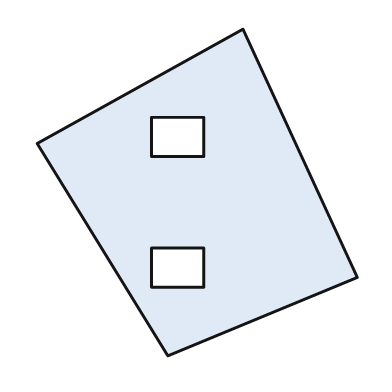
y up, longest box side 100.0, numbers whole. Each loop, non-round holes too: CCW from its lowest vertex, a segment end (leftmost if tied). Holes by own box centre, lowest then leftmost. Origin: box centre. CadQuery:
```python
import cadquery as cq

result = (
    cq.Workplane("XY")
    .moveTo(-9.0, -50.0)
    .lineTo(49.0, -26.0)
    .lineTo(14.0, 50.0)
    .lineTo(-49.0, 15.0)
    .close()
    .moveTo(-14.0, -29.0)
    .lineTo(2.0, -29.0)
    .lineTo(2.0, -17.0)
    .lineTo(-14.0, -17.0)
    .close()
    .moveTo(-14.0, 11.0)
    .lineTo(2.0, 11.0)
    .lineTo(2.0, 23.0)
    .lineTo(-14.0, 23.0)
    .close()
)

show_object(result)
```